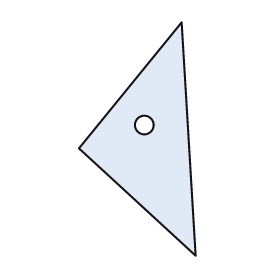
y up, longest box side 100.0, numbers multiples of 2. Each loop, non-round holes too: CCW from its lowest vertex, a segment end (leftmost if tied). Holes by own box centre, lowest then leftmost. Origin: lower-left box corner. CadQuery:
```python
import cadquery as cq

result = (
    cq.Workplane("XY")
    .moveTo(50.0, 0.0)
    .lineTo(44.0, 100.0)
    .lineTo(0.0, 46.0)
    .close()
    .moveTo(28.0, 56.0)
    .circle(4.0)
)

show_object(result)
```